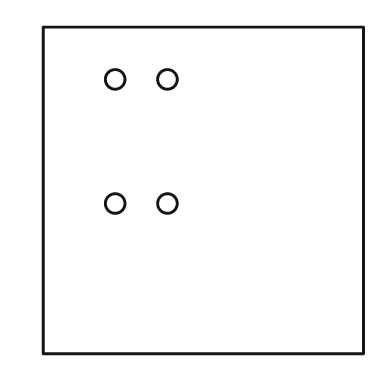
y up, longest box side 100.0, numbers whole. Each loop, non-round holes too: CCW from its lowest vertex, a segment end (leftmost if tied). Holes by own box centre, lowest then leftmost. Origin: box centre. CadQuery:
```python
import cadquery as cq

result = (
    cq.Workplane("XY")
    .moveTo(-49.0, -50.0)
    .lineTo(49.0, -50.0)
    .lineTo(49.0, 50.0)
    .lineTo(-49.0, 50.0)
    .close()
    .moveTo(-27.0, -4.0)
    .circle(3.0)
    .moveTo(-11.0, -4.0)
    .circle(3.0)
    .moveTo(-27.0, 34.0)
    .circle(3.0)
    .moveTo(-11.0, 34.0)
    .circle(3.0)
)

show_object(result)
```